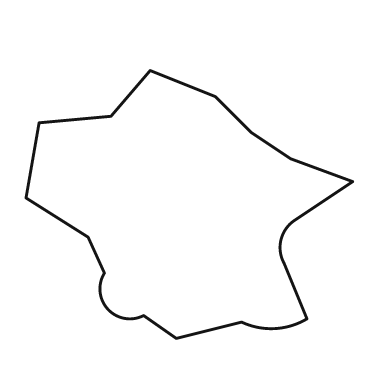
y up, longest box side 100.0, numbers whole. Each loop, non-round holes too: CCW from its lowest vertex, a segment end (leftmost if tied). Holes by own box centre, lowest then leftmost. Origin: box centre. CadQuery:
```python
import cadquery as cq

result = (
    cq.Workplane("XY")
    .moveTo(-4.0, -41.0)
    .lineTo(16.0, -36.0)
    .threePointArc((26.0, -38.0), (36.0, -35.0))
    .lineTo(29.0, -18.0)
    .threePointArc((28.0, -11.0), (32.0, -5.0))
    .lineTo(50.0, 7.0)
    .lineTo(31.0, 14.0)
    .lineTo(19.0, 22.0)
    .lineTo(8.0, 33.0)
    .lineTo(-12.0, 41.0)
    .lineTo(-24.0, 27.0)
    .lineTo(-46.0, 25.0)
    .lineTo(-50.0, 2.0)
    .lineTo(-31.0, -10.0)
    .lineTo(-26.0, -21.0)
    .threePointArc((-25.0, -32.0), (-14.0, -34.0))
    .close()
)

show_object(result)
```